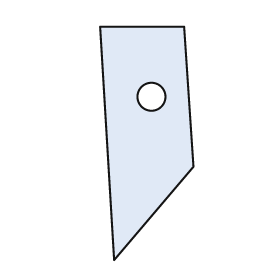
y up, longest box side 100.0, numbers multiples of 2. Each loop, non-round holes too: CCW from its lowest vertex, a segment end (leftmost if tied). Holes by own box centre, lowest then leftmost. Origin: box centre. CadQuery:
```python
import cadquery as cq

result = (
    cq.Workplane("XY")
    .moveTo(-14.0, -50.0)
    .lineTo(20.0, -10.0)
    .lineTo(16.0, 50.0)
    .lineTo(-20.0, 50.0)
    .close()
    .moveTo(2.0, 20.0)
    .circle(6.0)
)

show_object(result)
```